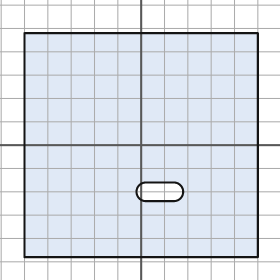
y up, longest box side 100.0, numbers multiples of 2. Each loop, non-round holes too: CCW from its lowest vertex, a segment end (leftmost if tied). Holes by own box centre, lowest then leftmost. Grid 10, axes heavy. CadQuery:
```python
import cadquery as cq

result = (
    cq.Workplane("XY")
    .moveTo(-50.0, -48.0)
    .lineTo(50.0, -48.0)
    .lineTo(50.0, 48.0)
    .lineTo(-50.0, 48.0)
    .close()
    .moveTo(2.0, -24.0)
    .lineTo(14.0, -24.0)
    .threePointArc((18.0, -20.0), (14.0, -16.0))
    .lineTo(2.0, -16.0)
    .threePointArc((-2.0, -20.0), (2.0, -24.0))
    .close()
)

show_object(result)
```